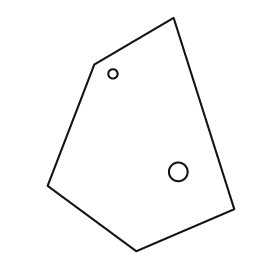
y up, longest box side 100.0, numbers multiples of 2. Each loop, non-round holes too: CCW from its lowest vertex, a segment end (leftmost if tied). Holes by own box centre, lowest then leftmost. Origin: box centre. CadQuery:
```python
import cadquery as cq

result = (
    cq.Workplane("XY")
    .moveTo(-2.0, -50.0)
    .lineTo(40.0, -32.0)
    .lineTo(14.0, 50.0)
    .lineTo(-20.0, 30.0)
    .lineTo(-40.0, -22.0)
    .close()
    .moveTo(16.0, -16.0)
    .circle(4.0)
    .moveTo(-12.0, 26.0)
    .circle(2.0)
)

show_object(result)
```